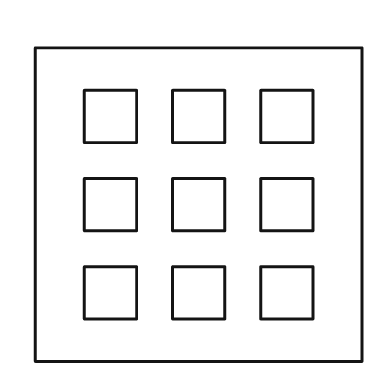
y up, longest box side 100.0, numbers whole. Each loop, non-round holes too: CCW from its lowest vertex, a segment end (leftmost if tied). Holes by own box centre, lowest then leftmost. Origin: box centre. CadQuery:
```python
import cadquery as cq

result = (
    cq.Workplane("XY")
    .moveTo(-50.0, -48.0)
    .lineTo(50.0, -48.0)
    .lineTo(50.0, 48.0)
    .lineTo(-50.0, 48.0)
    .close()
    .moveTo(-35.0, -35.0)
    .lineTo(-19.0, -35.0)
    .lineTo(-19.0, -19.0)
    .lineTo(-35.0, -19.0)
    .close()
    .moveTo(-8.0, -35.0)
    .lineTo(8.0, -35.0)
    .lineTo(8.0, -19.0)
    .lineTo(-8.0, -19.0)
    .close()
    .moveTo(19.0, -35.0)
    .lineTo(35.0, -35.0)
    .lineTo(35.0, -19.0)
    .lineTo(19.0, -19.0)
    .close()
    .moveTo(-35.0, -8.0)
    .lineTo(-19.0, -8.0)
    .lineTo(-19.0, 8.0)
    .lineTo(-35.0, 8.0)
    .close()
    .moveTo(-8.0, -8.0)
    .lineTo(8.0, -8.0)
    .lineTo(8.0, 8.0)
    .lineTo(-8.0, 8.0)
    .close()
    .moveTo(19.0, -8.0)
    .lineTo(35.0, -8.0)
    .lineTo(35.0, 8.0)
    .lineTo(19.0, 8.0)
    .close()
    .moveTo(-35.0, 19.0)
    .lineTo(-19.0, 19.0)
    .lineTo(-19.0, 35.0)
    .lineTo(-35.0, 35.0)
    .close()
    .moveTo(-8.0, 19.0)
    .lineTo(8.0, 19.0)
    .lineTo(8.0, 35.0)
    .lineTo(-8.0, 35.0)
    .close()
    .moveTo(19.0, 19.0)
    .lineTo(35.0, 19.0)
    .lineTo(35.0, 35.0)
    .lineTo(19.0, 35.0)
    .close()
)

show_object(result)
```